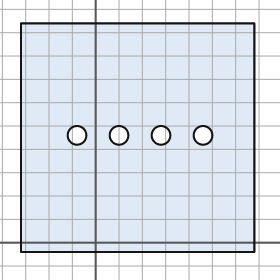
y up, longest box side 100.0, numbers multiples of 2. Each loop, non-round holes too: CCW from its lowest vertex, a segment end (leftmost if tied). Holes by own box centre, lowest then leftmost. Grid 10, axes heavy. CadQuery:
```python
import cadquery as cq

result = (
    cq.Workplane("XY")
    .moveTo(-32.0, -4.0)
    .lineTo(68.0, -4.0)
    .lineTo(68.0, 94.0)
    .lineTo(-32.0, 94.0)
    .close()
    .moveTo(-8.0, 46.0)
    .circle(4.0)
    .moveTo(10.0, 46.0)
    .circle(4.0)
    .moveTo(28.0, 46.0)
    .circle(4.0)
    .moveTo(46.0, 46.0)
    .circle(4.0)
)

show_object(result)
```